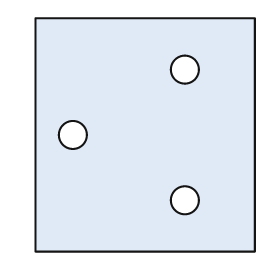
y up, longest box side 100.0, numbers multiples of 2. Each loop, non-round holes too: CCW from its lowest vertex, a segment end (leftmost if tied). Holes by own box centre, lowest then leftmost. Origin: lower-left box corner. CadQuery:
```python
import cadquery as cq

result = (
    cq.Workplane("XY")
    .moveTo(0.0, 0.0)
    .lineTo(94.0, 0.0)
    .lineTo(94.0, 100.0)
    .lineTo(0.0, 100.0)
    .close()
    .moveTo(64.0, 22.0)
    .circle(6.0)
    .moveTo(16.0, 50.0)
    .circle(6.0)
    .moveTo(64.0, 78.0)
    .circle(6.0)
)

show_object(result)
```